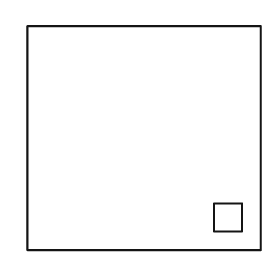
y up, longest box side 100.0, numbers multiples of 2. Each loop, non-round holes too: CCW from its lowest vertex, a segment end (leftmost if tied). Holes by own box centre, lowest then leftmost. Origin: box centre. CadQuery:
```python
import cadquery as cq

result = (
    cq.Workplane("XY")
    .moveTo(-50.0, -48.0)
    .lineTo(50.0, -48.0)
    .lineTo(50.0, 48.0)
    .lineTo(-50.0, 48.0)
    .close()
    .moveTo(30.0, -40.0)
    .lineTo(42.0, -40.0)
    .lineTo(42.0, -28.0)
    .lineTo(30.0, -28.0)
    .close()
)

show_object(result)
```